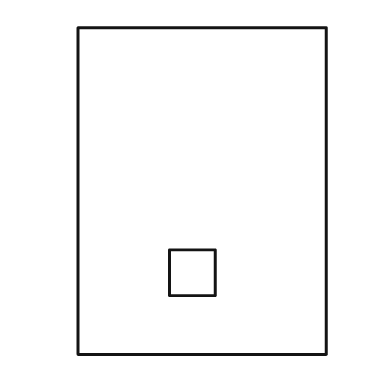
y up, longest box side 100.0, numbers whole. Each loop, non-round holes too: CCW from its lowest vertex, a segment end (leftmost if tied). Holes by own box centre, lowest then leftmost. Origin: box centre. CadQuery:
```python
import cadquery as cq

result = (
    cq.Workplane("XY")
    .moveTo(-38.0, -50.0)
    .lineTo(38.0, -50.0)
    .lineTo(38.0, 50.0)
    .lineTo(-38.0, 50.0)
    .close()
    .moveTo(-10.0, -32.0)
    .lineTo(4.0, -32.0)
    .lineTo(4.0, -18.0)
    .lineTo(-10.0, -18.0)
    .close()
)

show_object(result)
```